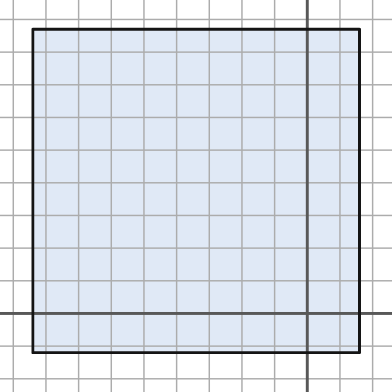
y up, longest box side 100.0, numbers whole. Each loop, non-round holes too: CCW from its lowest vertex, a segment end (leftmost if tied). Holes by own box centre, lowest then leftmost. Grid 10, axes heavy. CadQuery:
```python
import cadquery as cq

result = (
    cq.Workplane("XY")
    .moveTo(-84.0, -12.0)
    .lineTo(16.0, -12.0)
    .lineTo(16.0, 87.0)
    .lineTo(-84.0, 87.0)
    .close()
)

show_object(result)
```